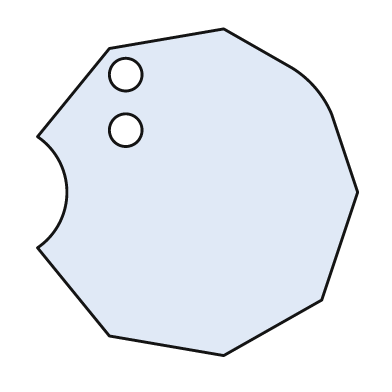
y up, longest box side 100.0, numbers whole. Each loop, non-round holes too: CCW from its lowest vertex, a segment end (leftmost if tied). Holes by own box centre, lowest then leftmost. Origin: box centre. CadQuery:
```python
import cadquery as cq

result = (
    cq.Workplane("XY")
    .moveTo(8.0, -50.0)
    .lineTo(38.0, -33.0)
    .lineTo(49.0, 0.0)
    .lineTo(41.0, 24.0)
    .threePointArc((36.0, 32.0), (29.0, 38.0))
    .lineTo(8.0, 50.0)
    .lineTo(-27.0, 44.0)
    .lineTo(-49.0, 17.0)
    .threePointArc((-40.0, 0.0), (-49.0, -17.0))
    .lineTo(-27.0, -44.0)
    .close()
    .moveTo(-22.0, 19.0)
    .circle(5.0)
    .moveTo(-22.0, 36.0)
    .circle(5.0)
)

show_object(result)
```